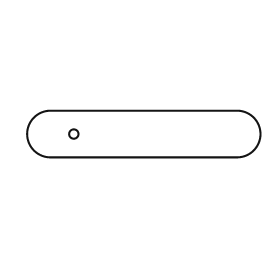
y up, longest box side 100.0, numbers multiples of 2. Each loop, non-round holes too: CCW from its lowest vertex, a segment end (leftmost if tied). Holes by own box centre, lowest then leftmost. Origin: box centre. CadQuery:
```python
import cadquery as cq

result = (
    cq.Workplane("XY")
    .moveTo(-40.0, -10.0)
    .lineTo(40.0, -10.0)
    .threePointArc((50.0, 0.0), (40.0, 10.0))
    .lineTo(-40.0, 10.0)
    .threePointArc((-50.0, 0.0), (-40.0, -10.0))
    .close()
    .moveTo(-30.0, 0.0)
    .circle(2.0)
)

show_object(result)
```